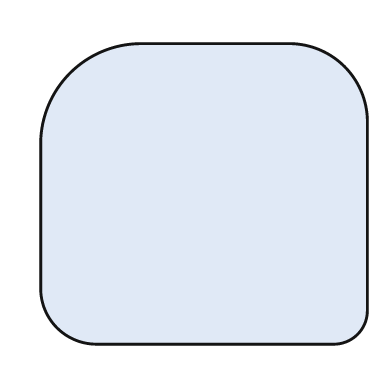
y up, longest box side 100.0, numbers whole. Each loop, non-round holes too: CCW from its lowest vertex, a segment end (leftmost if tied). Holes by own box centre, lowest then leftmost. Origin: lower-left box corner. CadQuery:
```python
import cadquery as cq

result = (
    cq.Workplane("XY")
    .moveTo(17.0, 0.0)
    .lineTo(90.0, 0.0)
    .threePointArc((97.0, 3.0), (100.0, 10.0))
    .lineTo(100.0, 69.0)
    .threePointArc((93.0, 85.0), (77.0, 92.0))
    .lineTo(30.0, 92.0)
    .threePointArc((9.0, 83.0), (0.0, 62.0))
    .lineTo(0.0, 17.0)
    .threePointArc((5.0, 5.0), (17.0, 0.0))
    .close()
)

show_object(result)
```